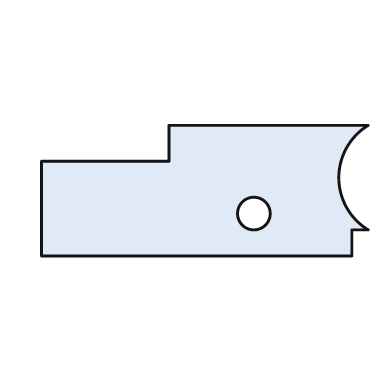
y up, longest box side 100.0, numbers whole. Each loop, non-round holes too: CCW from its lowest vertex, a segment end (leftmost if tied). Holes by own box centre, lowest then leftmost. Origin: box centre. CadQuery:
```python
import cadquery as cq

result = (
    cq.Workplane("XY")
    .moveTo(-50.0, -20.0)
    .lineTo(45.0, -20.0)
    .lineTo(45.0, -12.0)
    .lineTo(50.0, -12.0)
    .threePointArc((41.0, 4.0), (50.0, 20.0))
    .lineTo(-11.0, 20.0)
    .lineTo(-11.0, 9.0)
    .lineTo(-50.0, 9.0)
    .close()
    .moveTo(15.0, -7.0)
    .circle(5.0)
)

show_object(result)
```